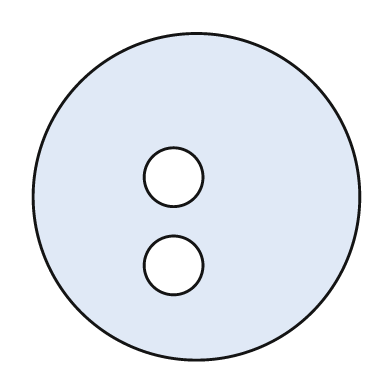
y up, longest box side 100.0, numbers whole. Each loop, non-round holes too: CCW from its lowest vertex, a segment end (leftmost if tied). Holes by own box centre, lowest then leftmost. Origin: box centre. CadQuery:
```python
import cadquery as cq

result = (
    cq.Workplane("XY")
    .moveTo(0.0, 0.0)
    .circle(50.0)
    .moveTo(-7.0, -21.0)
    .circle(9.0)
    .moveTo(-7.0, 6.0)
    .circle(9.0)
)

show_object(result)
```